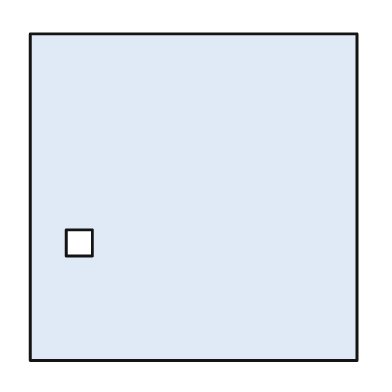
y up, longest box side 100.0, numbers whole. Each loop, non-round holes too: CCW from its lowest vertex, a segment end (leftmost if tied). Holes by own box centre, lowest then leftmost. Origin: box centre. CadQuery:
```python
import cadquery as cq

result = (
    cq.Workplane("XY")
    .moveTo(-50.0, -50.0)
    .lineTo(50.0, -50.0)
    .lineTo(50.0, 50.0)
    .lineTo(-50.0, 50.0)
    .close()
    .moveTo(-39.0, -18.0)
    .lineTo(-31.0, -18.0)
    .lineTo(-31.0, -10.0)
    .lineTo(-39.0, -10.0)
    .close()
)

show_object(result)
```